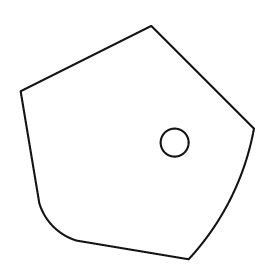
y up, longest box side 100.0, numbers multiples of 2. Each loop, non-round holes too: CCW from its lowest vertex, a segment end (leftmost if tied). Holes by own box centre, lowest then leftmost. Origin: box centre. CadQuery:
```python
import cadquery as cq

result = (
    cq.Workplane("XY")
    .moveTo(22.0, -50.0)
    .threePointArc((40.0, -24.0), (50.0, 6.0))
    .lineTo(6.0, 50.0)
    .lineTo(-50.0, 22.0)
    .lineTo(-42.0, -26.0)
    .threePointArc((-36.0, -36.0), (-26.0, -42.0))
    .close()
    .moveTo(16.0, 0.0)
    .circle(6.0)
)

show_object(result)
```